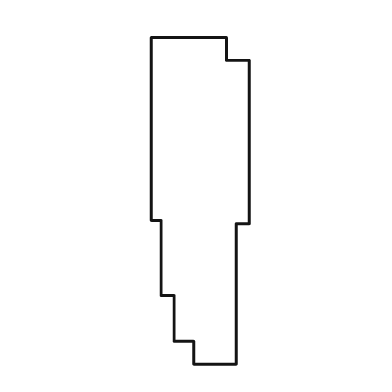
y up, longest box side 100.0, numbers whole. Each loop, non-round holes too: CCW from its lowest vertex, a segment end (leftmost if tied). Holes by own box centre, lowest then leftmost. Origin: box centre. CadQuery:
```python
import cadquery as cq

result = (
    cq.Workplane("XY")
    .moveTo(-2.0, -50.0)
    .lineTo(11.0, -50.0)
    .lineTo(11.0, -7.0)
    .lineTo(15.0, -7.0)
    .lineTo(15.0, 43.0)
    .lineTo(8.0, 43.0)
    .lineTo(8.0, 50.0)
    .lineTo(-15.0, 50.0)
    .lineTo(-15.0, -6.0)
    .lineTo(-12.0, -6.0)
    .lineTo(-12.0, -29.0)
    .lineTo(-8.0, -29.0)
    .lineTo(-8.0, -43.0)
    .lineTo(-2.0, -43.0)
    .close()
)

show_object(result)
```